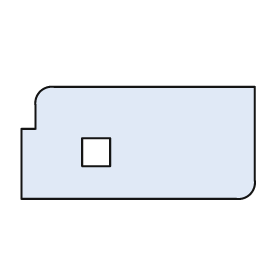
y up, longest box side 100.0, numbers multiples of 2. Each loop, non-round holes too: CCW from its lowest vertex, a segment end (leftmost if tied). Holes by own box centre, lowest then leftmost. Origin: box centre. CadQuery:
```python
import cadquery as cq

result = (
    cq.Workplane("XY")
    .moveTo(-50.0, -24.0)
    .lineTo(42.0, -24.0)
    .threePointArc((48.0, -22.0), (50.0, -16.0))
    .lineTo(50.0, 24.0)
    .lineTo(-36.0, 24.0)
    .threePointArc((-42.0, 22.0), (-44.0, 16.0))
    .lineTo(-44.0, 6.0)
    .lineTo(-50.0, 6.0)
    .close()
    .moveTo(-24.0, -10.0)
    .lineTo(-12.0, -10.0)
    .lineTo(-12.0, 2.0)
    .lineTo(-24.0, 2.0)
    .close()
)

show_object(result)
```